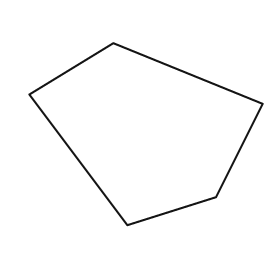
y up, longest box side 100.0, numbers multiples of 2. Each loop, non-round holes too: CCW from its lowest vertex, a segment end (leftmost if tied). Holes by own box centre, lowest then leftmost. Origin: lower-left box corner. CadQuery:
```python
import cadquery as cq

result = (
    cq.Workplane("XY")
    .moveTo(42.0, 0.0)
    .lineTo(80.0, 12.0)
    .lineTo(100.0, 52.0)
    .lineTo(36.0, 78.0)
    .lineTo(0.0, 56.0)
    .close()
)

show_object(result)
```